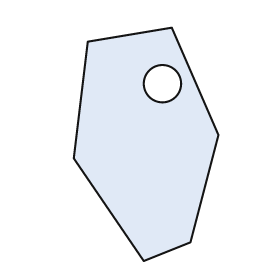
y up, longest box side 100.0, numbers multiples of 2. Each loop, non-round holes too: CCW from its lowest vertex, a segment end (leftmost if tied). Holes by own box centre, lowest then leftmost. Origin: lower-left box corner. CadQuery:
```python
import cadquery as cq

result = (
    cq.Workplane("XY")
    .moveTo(30.0, 0.0)
    .lineTo(50.0, 8.0)
    .lineTo(62.0, 54.0)
    .lineTo(42.0, 100.0)
    .lineTo(6.0, 94.0)
    .lineTo(0.0, 44.0)
    .close()
    .moveTo(38.0, 76.0)
    .circle(8.0)
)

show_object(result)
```